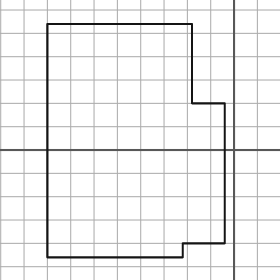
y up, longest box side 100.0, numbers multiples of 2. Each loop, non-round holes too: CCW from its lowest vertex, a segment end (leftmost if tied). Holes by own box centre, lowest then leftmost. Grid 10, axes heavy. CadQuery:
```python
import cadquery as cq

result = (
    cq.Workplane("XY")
    .moveTo(-80.0, -46.0)
    .lineTo(-22.0, -46.0)
    .lineTo(-22.0, -40.0)
    .lineTo(-4.0, -40.0)
    .lineTo(-4.0, 20.0)
    .lineTo(-18.0, 20.0)
    .lineTo(-18.0, 54.0)
    .lineTo(-80.0, 54.0)
    .close()
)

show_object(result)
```